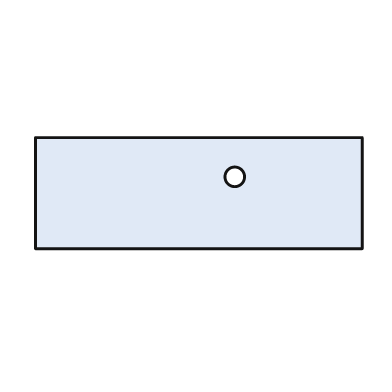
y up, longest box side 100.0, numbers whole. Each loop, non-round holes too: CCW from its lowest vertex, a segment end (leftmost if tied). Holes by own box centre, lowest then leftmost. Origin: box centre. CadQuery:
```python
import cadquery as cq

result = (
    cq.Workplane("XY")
    .moveTo(-50.0, -17.0)
    .lineTo(50.0, -17.0)
    .lineTo(50.0, 17.0)
    .lineTo(-50.0, 17.0)
    .close()
    .moveTo(11.0, 5.0)
    .circle(3.0)
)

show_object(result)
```